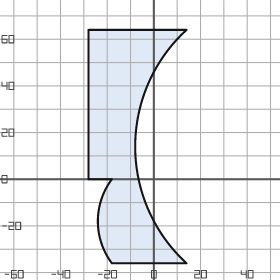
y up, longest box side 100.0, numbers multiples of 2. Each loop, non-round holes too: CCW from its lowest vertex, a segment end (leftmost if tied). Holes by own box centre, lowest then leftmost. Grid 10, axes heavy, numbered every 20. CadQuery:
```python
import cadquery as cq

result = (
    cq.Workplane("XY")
    .moveTo(-18.0, -36.0)
    .lineTo(14.0, -36.0)
    .threePointArc((-8.0, 14.0), (14.0, 64.0))
    .lineTo(-28.0, 64.0)
    .lineTo(-28.0, 0.0)
    .lineTo(-18.0, 0.0)
    .threePointArc((-24.0, -18.0), (-18.0, -36.0))
    .close()
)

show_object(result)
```